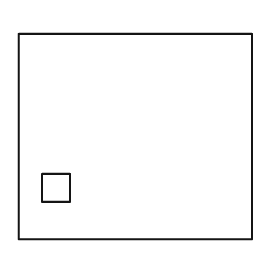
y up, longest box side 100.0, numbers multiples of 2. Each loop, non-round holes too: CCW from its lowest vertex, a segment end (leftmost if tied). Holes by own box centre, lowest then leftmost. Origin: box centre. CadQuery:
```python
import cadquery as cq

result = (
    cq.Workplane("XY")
    .moveTo(-50.0, -44.0)
    .lineTo(50.0, -44.0)
    .lineTo(50.0, 44.0)
    .lineTo(-50.0, 44.0)
    .close()
    .moveTo(-40.0, -28.0)
    .lineTo(-28.0, -28.0)
    .lineTo(-28.0, -16.0)
    .lineTo(-40.0, -16.0)
    .close()
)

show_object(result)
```